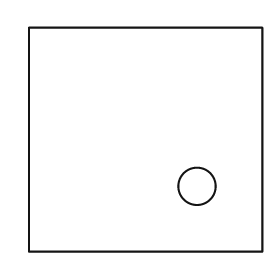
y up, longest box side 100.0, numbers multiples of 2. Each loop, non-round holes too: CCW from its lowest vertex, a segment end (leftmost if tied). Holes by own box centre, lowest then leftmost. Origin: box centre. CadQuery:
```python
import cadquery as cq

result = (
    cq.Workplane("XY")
    .moveTo(-50.0, -48.0)
    .lineTo(50.0, -48.0)
    .lineTo(50.0, 48.0)
    .lineTo(-50.0, 48.0)
    .close()
    .moveTo(22.0, -20.0)
    .circle(8.0)
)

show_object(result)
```